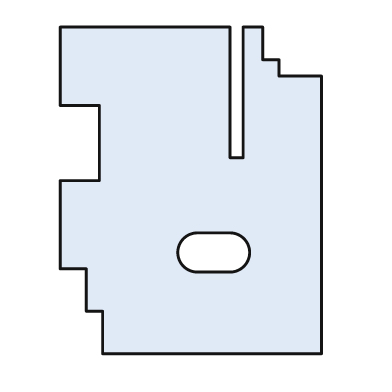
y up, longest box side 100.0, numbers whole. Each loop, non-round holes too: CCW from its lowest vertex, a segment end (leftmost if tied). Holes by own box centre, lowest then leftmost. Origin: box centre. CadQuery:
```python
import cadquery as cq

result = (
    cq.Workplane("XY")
    .moveTo(-27.0, -50.0)
    .lineTo(40.0, -50.0)
    .lineTo(40.0, 35.0)
    .lineTo(27.0, 35.0)
    .lineTo(27.0, 40.0)
    .lineTo(22.0, 40.0)
    .lineTo(22.0, 50.0)
    .lineTo(16.0, 50.0)
    .lineTo(16.0, 10.0)
    .lineTo(12.0, 10.0)
    .lineTo(12.0, 50.0)
    .lineTo(-40.0, 50.0)
    .lineTo(-40.0, 26.0)
    .lineTo(-28.0, 26.0)
    .lineTo(-28.0, 3.0)
    .lineTo(-40.0, 3.0)
    .lineTo(-40.0, -24.0)
    .lineTo(-32.0, -24.0)
    .lineTo(-32.0, -37.0)
    .lineTo(-27.0, -37.0)
    .close()
    .moveTo(2.0, -25.0)
    .lineTo(12.0, -25.0)
    .threePointArc((18.0, -19.0), (12.0, -13.0))
    .lineTo(2.0, -13.0)
    .threePointArc((-4.0, -19.0), (2.0, -25.0))
    .close()
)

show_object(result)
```